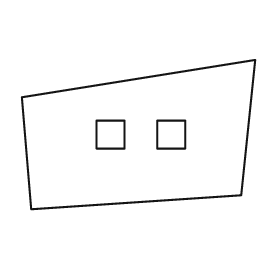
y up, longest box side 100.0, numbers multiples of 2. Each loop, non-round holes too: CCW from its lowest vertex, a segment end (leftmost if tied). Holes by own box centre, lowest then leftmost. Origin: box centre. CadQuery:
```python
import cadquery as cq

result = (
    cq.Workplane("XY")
    .moveTo(-46.0, -32.0)
    .lineTo(44.0, -26.0)
    .lineTo(50.0, 32.0)
    .lineTo(-50.0, 16.0)
    .close()
    .moveTo(-18.0, -6.0)
    .lineTo(-6.0, -6.0)
    .lineTo(-6.0, 6.0)
    .lineTo(-18.0, 6.0)
    .close()
    .moveTo(8.0, -6.0)
    .lineTo(20.0, -6.0)
    .lineTo(20.0, 6.0)
    .lineTo(8.0, 6.0)
    .close()
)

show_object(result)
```